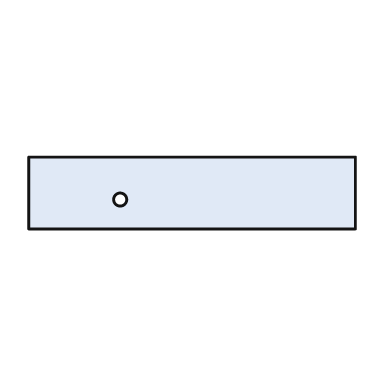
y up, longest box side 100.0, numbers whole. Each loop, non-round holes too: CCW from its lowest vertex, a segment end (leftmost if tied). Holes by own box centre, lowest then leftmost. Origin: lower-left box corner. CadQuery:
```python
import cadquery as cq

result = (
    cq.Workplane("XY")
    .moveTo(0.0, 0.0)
    .lineTo(100.0, 0.0)
    .lineTo(100.0, 22.0)
    .lineTo(0.0, 22.0)
    .close()
    .moveTo(28.0, 9.0)
    .circle(2.0)
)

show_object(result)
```